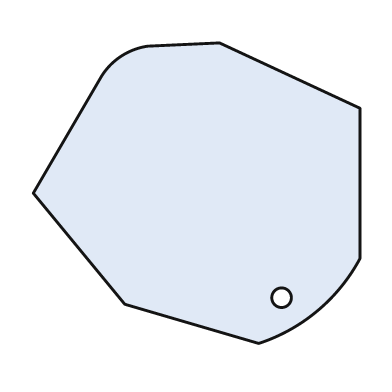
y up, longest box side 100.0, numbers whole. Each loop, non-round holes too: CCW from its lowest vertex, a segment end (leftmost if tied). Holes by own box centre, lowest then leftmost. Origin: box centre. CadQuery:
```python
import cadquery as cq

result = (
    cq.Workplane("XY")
    .moveTo(19.0, -46.0)
    .threePointArc((37.0, -36.0), (50.0, -20.0))
    .lineTo(50.0, 26.0)
    .lineTo(7.0, 46.0)
    .lineTo(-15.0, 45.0)
    .threePointArc((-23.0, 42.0), (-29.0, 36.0))
    .lineTo(-50.0, 0.0)
    .lineTo(-22.0, -34.0)
    .close()
    .moveTo(26.0, -32.0)
    .circle(3.0)
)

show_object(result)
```